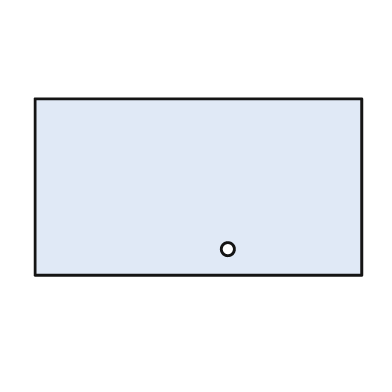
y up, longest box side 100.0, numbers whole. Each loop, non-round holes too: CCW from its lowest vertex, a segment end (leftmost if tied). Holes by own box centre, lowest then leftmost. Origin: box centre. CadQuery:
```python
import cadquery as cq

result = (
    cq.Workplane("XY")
    .moveTo(-50.0, -27.0)
    .lineTo(50.0, -27.0)
    .lineTo(50.0, 27.0)
    .lineTo(-50.0, 27.0)
    .close()
    .moveTo(9.0, -19.0)
    .circle(2.0)
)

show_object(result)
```